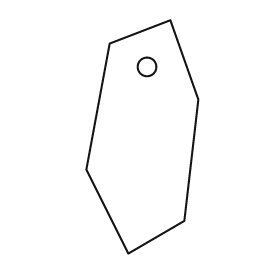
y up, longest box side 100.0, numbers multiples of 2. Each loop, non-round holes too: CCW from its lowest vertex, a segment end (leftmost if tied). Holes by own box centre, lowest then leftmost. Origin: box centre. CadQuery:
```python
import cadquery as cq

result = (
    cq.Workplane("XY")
    .moveTo(-6.0, -50.0)
    .lineTo(18.0, -36.0)
    .lineTo(24.0, 16.0)
    .lineTo(12.0, 50.0)
    .lineTo(-14.0, 40.0)
    .lineTo(-24.0, -14.0)
    .close()
    .moveTo(2.0, 30.0)
    .circle(4.0)
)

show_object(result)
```